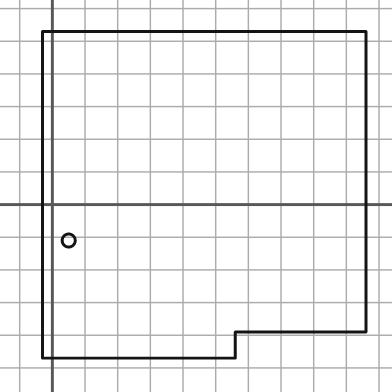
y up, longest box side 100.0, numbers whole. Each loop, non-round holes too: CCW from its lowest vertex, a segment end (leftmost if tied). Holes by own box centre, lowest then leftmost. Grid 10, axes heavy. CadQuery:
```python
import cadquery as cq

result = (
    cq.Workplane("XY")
    .moveTo(-3.0, -47.0)
    .lineTo(56.0, -47.0)
    .lineTo(56.0, -39.0)
    .lineTo(96.0, -39.0)
    .lineTo(96.0, 53.0)
    .lineTo(-3.0, 53.0)
    .close()
    .moveTo(5.0, -11.0)
    .circle(2.0)
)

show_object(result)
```